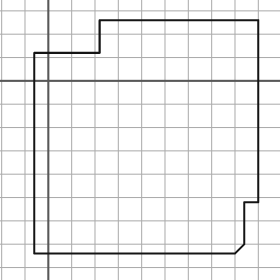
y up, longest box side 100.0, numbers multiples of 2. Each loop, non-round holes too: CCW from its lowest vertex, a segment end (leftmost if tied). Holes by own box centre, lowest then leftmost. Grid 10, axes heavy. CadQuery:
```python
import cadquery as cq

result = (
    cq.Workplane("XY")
    .moveTo(-6.0, -74.0)
    .lineTo(80.0, -74.0)
    .lineTo(84.0, -70.0)
    .lineTo(84.0, -52.0)
    .lineTo(90.0, -52.0)
    .lineTo(90.0, 26.0)
    .lineTo(22.0, 26.0)
    .lineTo(22.0, 12.0)
    .lineTo(-6.0, 12.0)
    .close()
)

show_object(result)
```